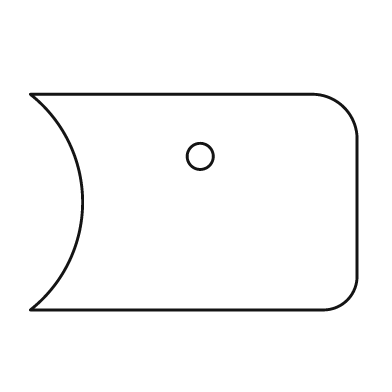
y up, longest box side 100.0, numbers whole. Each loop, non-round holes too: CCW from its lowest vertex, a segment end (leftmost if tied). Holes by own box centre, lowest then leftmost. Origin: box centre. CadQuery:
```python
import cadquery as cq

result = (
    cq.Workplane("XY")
    .moveTo(-50.0, -33.0)
    .lineTo(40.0, -33.0)
    .threePointArc((47.0, -30.0), (50.0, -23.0))
    .lineTo(50.0, 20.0)
    .threePointArc((46.0, 29.0), (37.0, 33.0))
    .lineTo(-50.0, 33.0)
    .threePointArc((-34.0, 0.0), (-50.0, -33.0))
    .close()
    .moveTo(2.0, 14.0)
    .circle(4.0)
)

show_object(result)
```